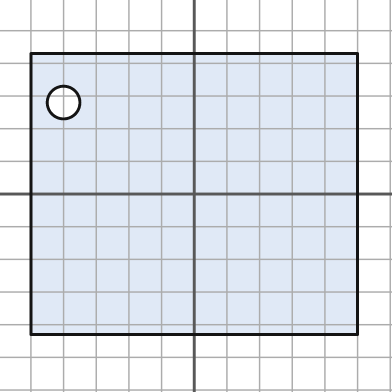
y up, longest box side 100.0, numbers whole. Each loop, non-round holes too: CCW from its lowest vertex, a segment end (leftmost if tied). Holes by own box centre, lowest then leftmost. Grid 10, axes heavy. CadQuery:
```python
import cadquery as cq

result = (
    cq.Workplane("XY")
    .moveTo(-50.0, -43.0)
    .lineTo(50.0, -43.0)
    .lineTo(50.0, 43.0)
    .lineTo(-50.0, 43.0)
    .close()
    .moveTo(-40.0, 28.0)
    .circle(5.0)
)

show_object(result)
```